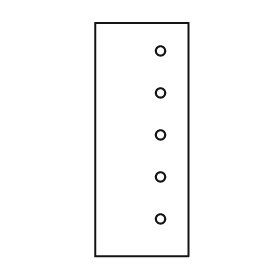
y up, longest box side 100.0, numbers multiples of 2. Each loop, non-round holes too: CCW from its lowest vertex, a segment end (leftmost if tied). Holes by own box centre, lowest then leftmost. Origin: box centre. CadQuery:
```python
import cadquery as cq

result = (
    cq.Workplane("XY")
    .moveTo(-20.0, -50.0)
    .lineTo(20.0, -50.0)
    .lineTo(20.0, 50.0)
    .lineTo(-20.0, 50.0)
    .close()
    .moveTo(8.0, -34.0)
    .circle(2.0)
    .moveTo(8.0, -16.0)
    .circle(2.0)
    .moveTo(8.0, 2.0)
    .circle(2.0)
    .moveTo(8.0, 20.0)
    .circle(2.0)
    .moveTo(8.0, 38.0)
    .circle(2.0)
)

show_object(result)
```